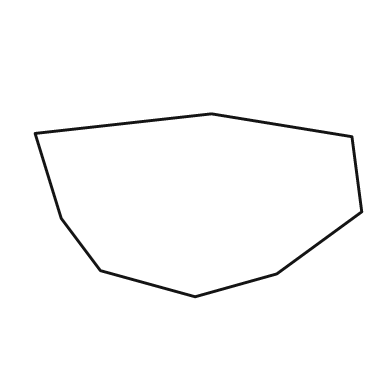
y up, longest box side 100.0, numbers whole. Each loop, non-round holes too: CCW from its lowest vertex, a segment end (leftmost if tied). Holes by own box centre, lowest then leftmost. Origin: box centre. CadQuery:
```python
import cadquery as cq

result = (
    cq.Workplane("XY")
    .moveTo(-1.0, -28.0)
    .lineTo(24.0, -21.0)
    .lineTo(50.0, -2.0)
    .lineTo(47.0, 21.0)
    .lineTo(4.0, 28.0)
    .lineTo(-50.0, 22.0)
    .lineTo(-42.0, -4.0)
    .lineTo(-30.0, -20.0)
    .close()
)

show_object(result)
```